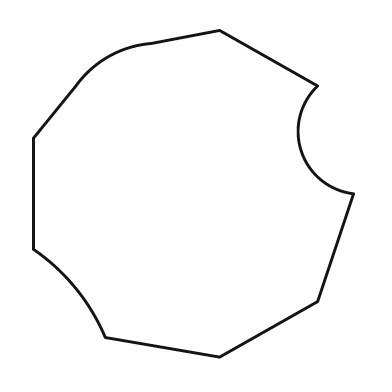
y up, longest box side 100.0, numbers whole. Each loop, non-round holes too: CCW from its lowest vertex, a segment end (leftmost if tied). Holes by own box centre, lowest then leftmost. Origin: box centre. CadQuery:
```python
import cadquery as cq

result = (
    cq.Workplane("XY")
    .moveTo(8.0, -50.0)
    .lineTo(38.0, -33.0)
    .lineTo(49.0, 0.0)
    .threePointArc((33.0, 13.0), (38.0, 33.0))
    .lineTo(8.0, 50.0)
    .lineTo(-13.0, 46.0)
    .threePointArc((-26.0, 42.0), (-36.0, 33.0))
    .lineTo(-49.0, 17.0)
    .lineTo(-49.0, -17.0)
    .threePointArc((-36.0, -29.0), (-27.0, -44.0))
    .close()
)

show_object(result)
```